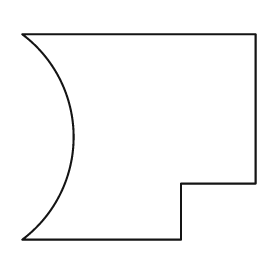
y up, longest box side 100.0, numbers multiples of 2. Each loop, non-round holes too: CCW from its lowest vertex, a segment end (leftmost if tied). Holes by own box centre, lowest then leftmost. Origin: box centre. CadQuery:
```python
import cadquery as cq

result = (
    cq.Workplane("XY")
    .moveTo(-50.0, -44.0)
    .lineTo(18.0, -44.0)
    .lineTo(18.0, -20.0)
    .lineTo(50.0, -20.0)
    .lineTo(50.0, 44.0)
    .lineTo(-50.0, 44.0)
    .threePointArc((-28.0, 0.0), (-50.0, -44.0))
    .close()
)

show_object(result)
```